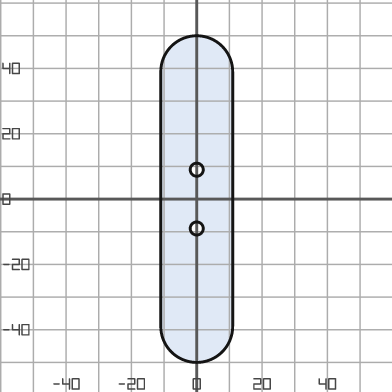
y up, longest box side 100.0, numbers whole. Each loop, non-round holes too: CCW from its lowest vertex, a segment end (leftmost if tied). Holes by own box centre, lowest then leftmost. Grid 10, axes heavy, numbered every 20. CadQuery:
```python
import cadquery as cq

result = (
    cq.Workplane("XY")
    .moveTo(-11.0, -39.0)
    .threePointArc((0.0, -50.0), (11.0, -39.0))
    .lineTo(11.0, 39.0)
    .threePointArc((0.0, 50.0), (-11.0, 39.0))
    .close()
    .moveTo(0.0, -9.0)
    .circle(2.0)
    .moveTo(0.0, 9.0)
    .circle(2.0)
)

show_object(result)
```